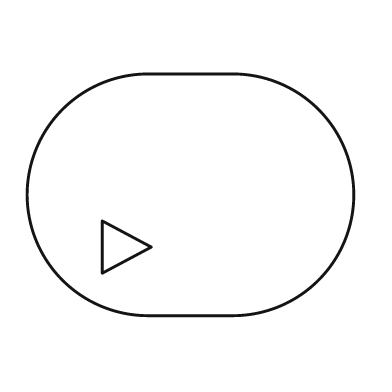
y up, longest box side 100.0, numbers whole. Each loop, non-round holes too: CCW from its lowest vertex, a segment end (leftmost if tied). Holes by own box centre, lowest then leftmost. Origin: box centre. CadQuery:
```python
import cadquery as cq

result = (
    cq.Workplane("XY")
    .moveTo(-13.0, -37.0)
    .lineTo(13.0, -37.0)
    .threePointArc((50.0, 0.0), (13.0, 37.0))
    .lineTo(-13.0, 37.0)
    .threePointArc((-50.0, 0.0), (-13.0, -37.0))
    .close()
    .moveTo(-27.0, -24.0)
    .lineTo(-12.0, -16.0)
    .lineTo(-27.0, -8.0)
    .close()
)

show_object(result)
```